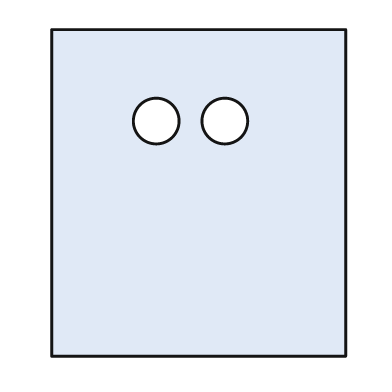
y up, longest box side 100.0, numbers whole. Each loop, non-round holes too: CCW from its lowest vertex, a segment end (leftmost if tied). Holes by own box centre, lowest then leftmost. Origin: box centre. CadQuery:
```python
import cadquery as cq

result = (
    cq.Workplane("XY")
    .moveTo(-45.0, -50.0)
    .lineTo(45.0, -50.0)
    .lineTo(45.0, 50.0)
    .lineTo(-45.0, 50.0)
    .close()
    .moveTo(-13.0, 22.0)
    .circle(7.0)
    .moveTo(8.0, 22.0)
    .circle(7.0)
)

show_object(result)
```